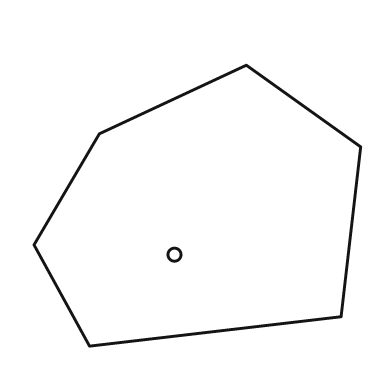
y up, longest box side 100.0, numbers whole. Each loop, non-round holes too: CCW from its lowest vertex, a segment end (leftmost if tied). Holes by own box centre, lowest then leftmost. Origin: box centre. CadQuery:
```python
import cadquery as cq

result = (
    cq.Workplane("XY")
    .moveTo(-33.0, -43.0)
    .lineTo(44.0, -34.0)
    .lineTo(50.0, 18.0)
    .lineTo(15.0, 43.0)
    .lineTo(-30.0, 22.0)
    .lineTo(-50.0, -12.0)
    .close()
    .moveTo(-7.0, -15.0)
    .circle(2.0)
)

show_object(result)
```